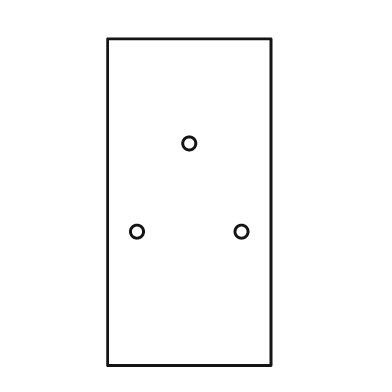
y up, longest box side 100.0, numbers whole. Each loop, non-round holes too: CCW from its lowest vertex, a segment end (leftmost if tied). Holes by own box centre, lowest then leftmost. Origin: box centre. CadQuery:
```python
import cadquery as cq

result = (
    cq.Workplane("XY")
    .moveTo(-25.0, -50.0)
    .lineTo(25.0, -50.0)
    .lineTo(25.0, 50.0)
    .lineTo(-25.0, 50.0)
    .close()
    .moveTo(-16.0, -9.0)
    .circle(2.0)
    .moveTo(16.0, -9.0)
    .circle(2.0)
    .moveTo(0.0, 18.0)
    .circle(2.0)
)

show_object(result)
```